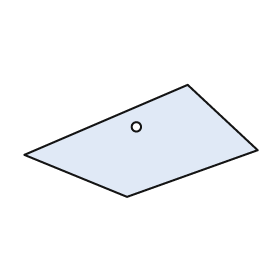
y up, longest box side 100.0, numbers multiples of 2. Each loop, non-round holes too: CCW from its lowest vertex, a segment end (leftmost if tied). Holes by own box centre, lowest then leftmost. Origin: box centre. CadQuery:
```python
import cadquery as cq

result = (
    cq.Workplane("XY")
    .moveTo(-6.0, -24.0)
    .lineTo(50.0, -4.0)
    .lineTo(20.0, 24.0)
    .lineTo(-50.0, -6.0)
    .close()
    .moveTo(-2.0, 6.0)
    .circle(2.0)
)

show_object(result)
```